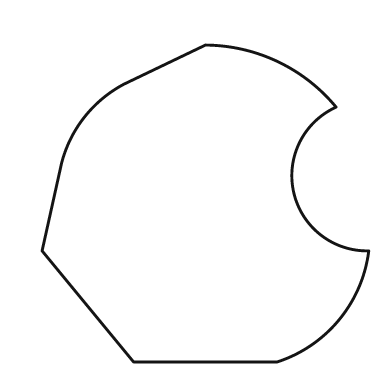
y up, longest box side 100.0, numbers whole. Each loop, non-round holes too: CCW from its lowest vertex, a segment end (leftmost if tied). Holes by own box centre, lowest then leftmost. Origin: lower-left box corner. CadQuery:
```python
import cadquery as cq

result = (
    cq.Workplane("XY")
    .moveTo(28.0, 0.0)
    .lineTo(72.0, 0.0)
    .threePointArc((91.0, 13.0), (100.0, 34.0))
    .threePointArc((77.0, 52.0), (90.0, 78.0))
    .threePointArc((72.0, 92.0), (50.0, 97.0))
    .lineTo(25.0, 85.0)
    .threePointArc((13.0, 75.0), (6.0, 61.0))
    .lineTo(0.0, 34.0)
    .close()
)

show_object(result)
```